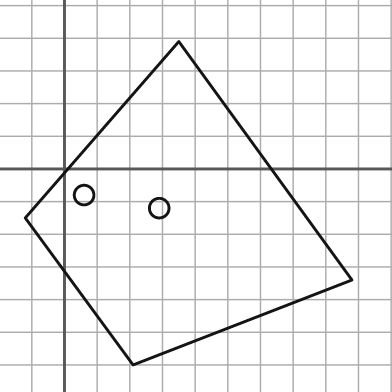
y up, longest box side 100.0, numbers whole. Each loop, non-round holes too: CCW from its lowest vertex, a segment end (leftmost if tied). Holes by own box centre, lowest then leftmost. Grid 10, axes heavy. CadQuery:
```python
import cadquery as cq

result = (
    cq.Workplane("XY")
    .moveTo(21.0, -60.0)
    .lineTo(88.0, -34.0)
    .lineTo(35.0, 39.0)
    .lineTo(-12.0, -15.0)
    .close()
    .moveTo(29.0, -12.0)
    .circle(3.0)
    .moveTo(6.0, -8.0)
    .circle(3.0)
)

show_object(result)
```